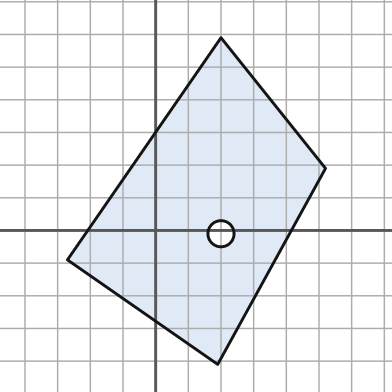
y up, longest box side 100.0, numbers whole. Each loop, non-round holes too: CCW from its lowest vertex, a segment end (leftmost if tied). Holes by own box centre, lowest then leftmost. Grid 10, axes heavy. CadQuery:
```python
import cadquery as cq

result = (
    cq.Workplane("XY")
    .moveTo(19.0, -41.0)
    .lineTo(52.0, 19.0)
    .lineTo(20.0, 59.0)
    .lineTo(-27.0, -9.0)
    .close()
    .moveTo(20.0, -1.0)
    .circle(4.0)
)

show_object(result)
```